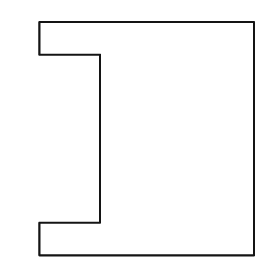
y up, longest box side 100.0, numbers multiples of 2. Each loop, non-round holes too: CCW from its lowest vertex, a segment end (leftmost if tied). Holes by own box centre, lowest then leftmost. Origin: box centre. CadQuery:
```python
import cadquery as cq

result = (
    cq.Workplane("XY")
    .moveTo(-46.0, -50.0)
    .lineTo(46.0, -50.0)
    .lineTo(46.0, 50.0)
    .lineTo(-46.0, 50.0)
    .lineTo(-46.0, 36.0)
    .lineTo(-20.0, 36.0)
    .lineTo(-20.0, -36.0)
    .lineTo(-46.0, -36.0)
    .close()
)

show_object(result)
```